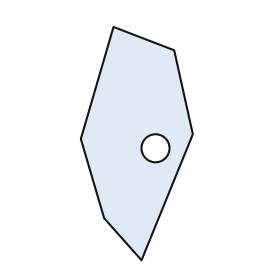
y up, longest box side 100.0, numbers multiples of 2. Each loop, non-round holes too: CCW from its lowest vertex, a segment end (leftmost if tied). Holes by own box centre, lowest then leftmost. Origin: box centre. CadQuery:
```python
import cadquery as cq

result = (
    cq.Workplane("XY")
    .moveTo(2.0, -50.0)
    .lineTo(24.0, 4.0)
    .lineTo(16.0, 40.0)
    .lineTo(-10.0, 50.0)
    .lineTo(-24.0, 2.0)
    .lineTo(-14.0, -32.0)
    .close()
    .moveTo(8.0, -2.0)
    .circle(6.0)
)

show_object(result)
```